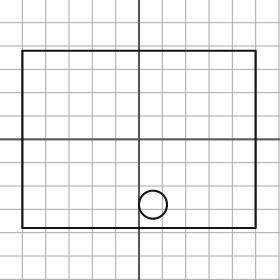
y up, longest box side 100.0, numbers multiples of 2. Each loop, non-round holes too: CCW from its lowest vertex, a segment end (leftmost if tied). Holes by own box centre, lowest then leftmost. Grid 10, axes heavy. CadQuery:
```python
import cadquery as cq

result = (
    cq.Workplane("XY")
    .moveTo(-50.0, -38.0)
    .lineTo(50.0, -38.0)
    .lineTo(50.0, 38.0)
    .lineTo(-50.0, 38.0)
    .close()
    .moveTo(6.0, -28.0)
    .circle(6.0)
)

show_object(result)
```